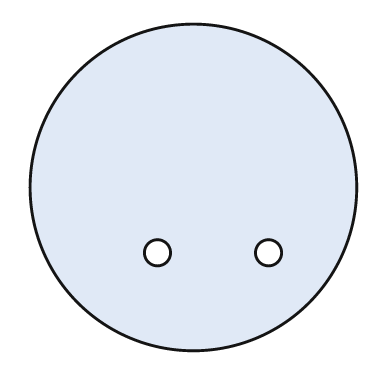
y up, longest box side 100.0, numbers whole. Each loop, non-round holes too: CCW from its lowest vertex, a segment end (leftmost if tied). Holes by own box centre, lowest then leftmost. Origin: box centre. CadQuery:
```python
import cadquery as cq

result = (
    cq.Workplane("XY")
    .moveTo(0.0, 0.0)
    .circle(50.0)
    .moveTo(-11.0, -20.0)
    .circle(4.0)
    .moveTo(23.0, -20.0)
    .circle(4.0)
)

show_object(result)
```